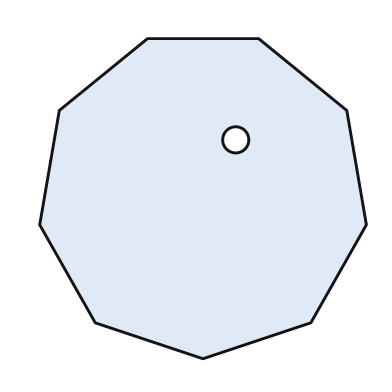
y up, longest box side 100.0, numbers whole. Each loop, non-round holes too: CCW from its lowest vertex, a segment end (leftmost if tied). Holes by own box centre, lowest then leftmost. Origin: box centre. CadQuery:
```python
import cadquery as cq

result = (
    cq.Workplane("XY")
    .moveTo(0.0, -49.0)
    .lineTo(33.0, -38.0)
    .lineTo(50.0, -8.0)
    .lineTo(44.0, 27.0)
    .lineTo(17.0, 49.0)
    .lineTo(-17.0, 49.0)
    .lineTo(-44.0, 27.0)
    .lineTo(-50.0, -8.0)
    .lineTo(-33.0, -38.0)
    .close()
    .moveTo(10.0, 18.0)
    .circle(4.0)
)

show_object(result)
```